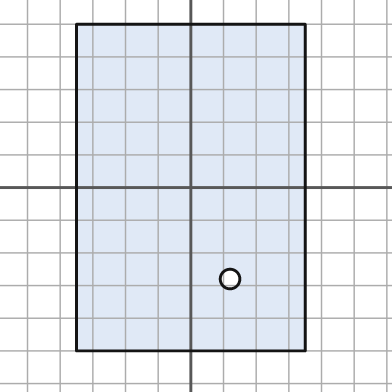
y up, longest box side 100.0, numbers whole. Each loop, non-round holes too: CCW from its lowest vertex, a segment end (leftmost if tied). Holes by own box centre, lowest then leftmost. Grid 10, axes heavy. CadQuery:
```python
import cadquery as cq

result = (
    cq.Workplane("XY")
    .moveTo(-35.0, -50.0)
    .lineTo(35.0, -50.0)
    .lineTo(35.0, 50.0)
    .lineTo(-35.0, 50.0)
    .close()
    .moveTo(12.0, -28.0)
    .circle(3.0)
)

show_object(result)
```